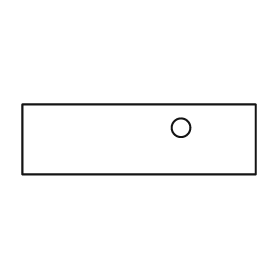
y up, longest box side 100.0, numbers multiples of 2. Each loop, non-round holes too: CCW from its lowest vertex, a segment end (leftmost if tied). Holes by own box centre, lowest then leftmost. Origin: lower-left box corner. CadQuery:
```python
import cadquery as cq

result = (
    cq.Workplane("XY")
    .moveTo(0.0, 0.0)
    .lineTo(100.0, 0.0)
    .lineTo(100.0, 30.0)
    .lineTo(0.0, 30.0)
    .close()
    .moveTo(68.0, 20.0)
    .circle(4.0)
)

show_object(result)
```